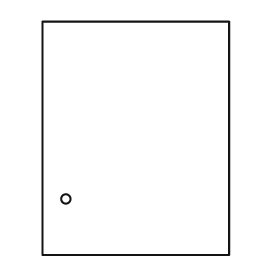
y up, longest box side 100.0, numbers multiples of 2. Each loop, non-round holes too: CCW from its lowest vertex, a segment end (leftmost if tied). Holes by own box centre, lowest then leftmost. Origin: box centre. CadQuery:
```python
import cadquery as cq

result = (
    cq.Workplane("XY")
    .moveTo(-40.0, -50.0)
    .lineTo(40.0, -50.0)
    .lineTo(40.0, 50.0)
    .lineTo(-40.0, 50.0)
    .close()
    .moveTo(-30.0, -26.0)
    .circle(2.0)
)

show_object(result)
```